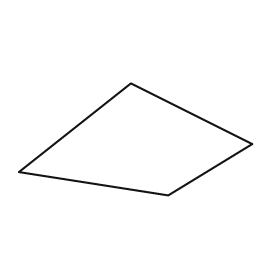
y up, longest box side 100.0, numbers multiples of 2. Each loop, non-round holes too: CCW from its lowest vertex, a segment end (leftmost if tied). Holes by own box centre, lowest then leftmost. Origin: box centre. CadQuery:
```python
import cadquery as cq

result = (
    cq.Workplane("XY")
    .moveTo(14.0, -24.0)
    .lineTo(50.0, -2.0)
    .lineTo(-2.0, 24.0)
    .lineTo(-50.0, -14.0)
    .close()
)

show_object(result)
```